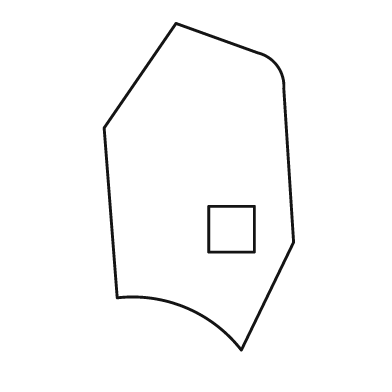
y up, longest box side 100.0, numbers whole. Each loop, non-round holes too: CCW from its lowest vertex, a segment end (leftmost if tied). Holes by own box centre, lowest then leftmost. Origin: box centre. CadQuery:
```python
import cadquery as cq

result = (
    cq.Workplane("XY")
    .moveTo(13.0, -50.0)
    .lineTo(29.0, -17.0)
    .lineTo(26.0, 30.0)
    .threePointArc((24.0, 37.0), (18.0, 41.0))
    .lineTo(-7.0, 50.0)
    .lineTo(-29.0, 18.0)
    .lineTo(-25.0, -34.0)
    .threePointArc((-4.0, -37.0), (13.0, -50.0))
    .close()
    .moveTo(3.0, -20.0)
    .lineTo(17.0, -20.0)
    .lineTo(17.0, -6.0)
    .lineTo(3.0, -6.0)
    .close()
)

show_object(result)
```